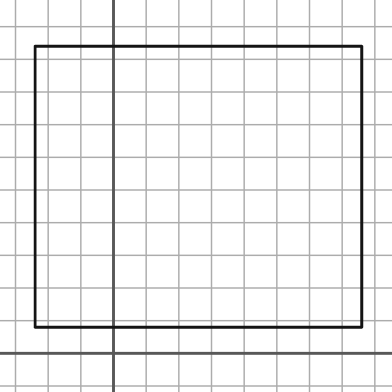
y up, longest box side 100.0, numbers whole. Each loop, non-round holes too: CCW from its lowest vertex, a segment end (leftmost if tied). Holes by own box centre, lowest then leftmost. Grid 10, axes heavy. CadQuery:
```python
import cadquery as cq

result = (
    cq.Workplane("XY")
    .moveTo(-24.0, 8.0)
    .lineTo(76.0, 8.0)
    .lineTo(76.0, 94.0)
    .lineTo(-24.0, 94.0)
    .close()
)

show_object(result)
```